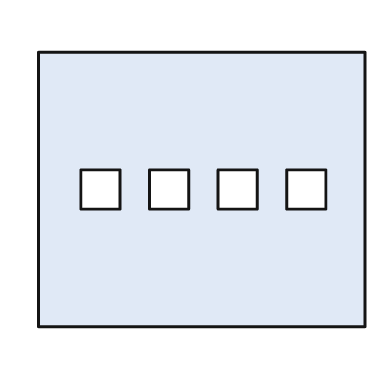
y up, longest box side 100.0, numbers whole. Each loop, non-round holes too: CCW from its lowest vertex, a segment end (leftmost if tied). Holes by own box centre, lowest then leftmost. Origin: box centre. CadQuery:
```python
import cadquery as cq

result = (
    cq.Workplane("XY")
    .moveTo(-50.0, -42.0)
    .lineTo(50.0, -42.0)
    .lineTo(50.0, 42.0)
    .lineTo(-50.0, 42.0)
    .close()
    .moveTo(-37.0, -6.0)
    .lineTo(-25.0, -6.0)
    .lineTo(-25.0, 6.0)
    .lineTo(-37.0, 6.0)
    .close()
    .moveTo(-16.0, -6.0)
    .lineTo(-4.0, -6.0)
    .lineTo(-4.0, 6.0)
    .lineTo(-16.0, 6.0)
    .close()
    .moveTo(5.0, -6.0)
    .lineTo(17.0, -6.0)
    .lineTo(17.0, 6.0)
    .lineTo(5.0, 6.0)
    .close()
    .moveTo(26.0, -6.0)
    .lineTo(38.0, -6.0)
    .lineTo(38.0, 6.0)
    .lineTo(26.0, 6.0)
    .close()
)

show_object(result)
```